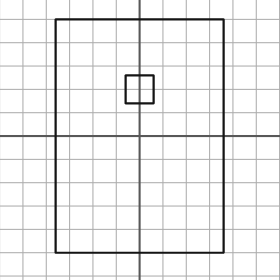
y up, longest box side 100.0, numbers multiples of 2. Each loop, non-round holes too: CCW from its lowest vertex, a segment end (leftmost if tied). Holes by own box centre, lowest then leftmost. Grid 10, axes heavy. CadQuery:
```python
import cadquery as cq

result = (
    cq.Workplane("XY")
    .moveTo(-36.0, -50.0)
    .lineTo(36.0, -50.0)
    .lineTo(36.0, 50.0)
    .lineTo(-36.0, 50.0)
    .close()
    .moveTo(-6.0, 14.0)
    .lineTo(6.0, 14.0)
    .lineTo(6.0, 26.0)
    .lineTo(-6.0, 26.0)
    .close()
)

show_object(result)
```